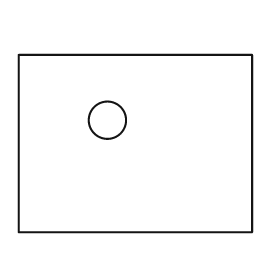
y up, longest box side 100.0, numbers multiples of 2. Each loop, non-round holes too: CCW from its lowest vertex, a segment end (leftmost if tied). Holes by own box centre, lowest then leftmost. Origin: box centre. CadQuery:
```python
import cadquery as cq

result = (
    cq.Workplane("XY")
    .moveTo(-50.0, -38.0)
    .lineTo(50.0, -38.0)
    .lineTo(50.0, 38.0)
    .lineTo(-50.0, 38.0)
    .close()
    .moveTo(-12.0, 10.0)
    .circle(8.0)
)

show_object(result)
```